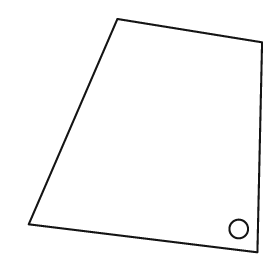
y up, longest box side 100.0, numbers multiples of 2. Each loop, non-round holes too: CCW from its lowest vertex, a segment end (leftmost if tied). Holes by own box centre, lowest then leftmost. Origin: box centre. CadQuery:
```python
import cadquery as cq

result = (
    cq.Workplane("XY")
    .moveTo(48.0, -50.0)
    .lineTo(50.0, 40.0)
    .lineTo(-12.0, 50.0)
    .lineTo(-50.0, -38.0)
    .close()
    .moveTo(40.0, -40.0)
    .circle(4.0)
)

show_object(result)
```